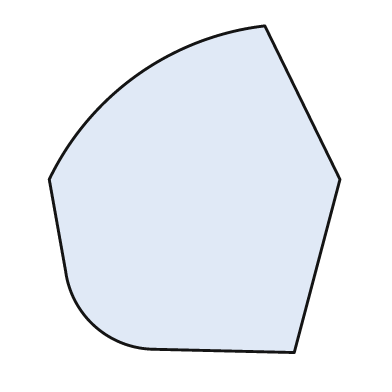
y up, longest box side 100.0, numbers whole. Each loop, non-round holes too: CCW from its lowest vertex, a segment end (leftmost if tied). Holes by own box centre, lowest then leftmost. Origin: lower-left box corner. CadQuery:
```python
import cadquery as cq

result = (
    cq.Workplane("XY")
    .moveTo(75.0, 0.0)
    .lineTo(89.0, 53.0)
    .lineTo(66.0, 100.0)
    .threePointArc((27.0, 85.0), (0.0, 53.0))
    .lineTo(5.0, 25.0)
    .threePointArc((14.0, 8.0), (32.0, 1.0))
    .close()
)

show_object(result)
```